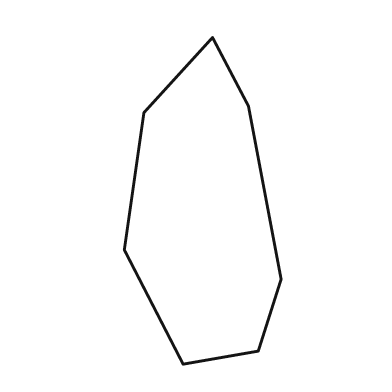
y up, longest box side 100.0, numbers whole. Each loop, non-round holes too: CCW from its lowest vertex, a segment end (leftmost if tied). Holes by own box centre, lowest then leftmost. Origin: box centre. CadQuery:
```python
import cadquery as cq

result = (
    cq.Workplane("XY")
    .moveTo(-6.0, -50.0)
    .lineTo(17.0, -46.0)
    .lineTo(24.0, -24.0)
    .lineTo(14.0, 29.0)
    .lineTo(3.0, 50.0)
    .lineTo(-18.0, 27.0)
    .lineTo(-24.0, -15.0)
    .close()
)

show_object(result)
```